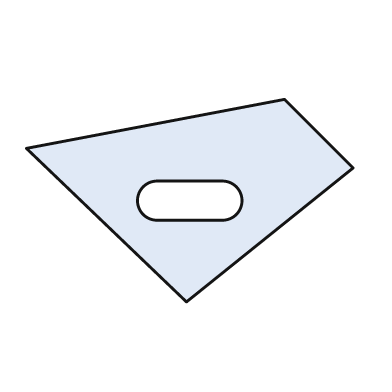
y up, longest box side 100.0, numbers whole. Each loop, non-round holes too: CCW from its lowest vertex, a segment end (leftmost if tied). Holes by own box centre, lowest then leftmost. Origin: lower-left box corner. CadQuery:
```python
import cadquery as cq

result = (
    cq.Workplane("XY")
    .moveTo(49.0, 0.0)
    .lineTo(100.0, 41.0)
    .lineTo(79.0, 62.0)
    .lineTo(0.0, 47.0)
    .close()
    .moveTo(40.0, 25.0)
    .lineTo(60.0, 25.0)
    .threePointArc((66.0, 31.0), (60.0, 37.0))
    .lineTo(40.0, 37.0)
    .threePointArc((34.0, 31.0), (40.0, 25.0))
    .close()
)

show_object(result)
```